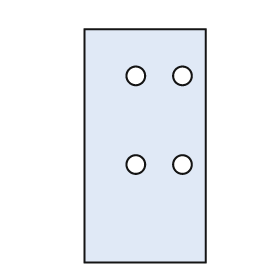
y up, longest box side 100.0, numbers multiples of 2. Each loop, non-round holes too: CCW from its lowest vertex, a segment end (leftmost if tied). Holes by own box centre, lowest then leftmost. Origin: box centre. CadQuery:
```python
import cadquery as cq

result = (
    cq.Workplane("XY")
    .moveTo(-26.0, -50.0)
    .lineTo(26.0, -50.0)
    .lineTo(26.0, 50.0)
    .lineTo(-26.0, 50.0)
    .close()
    .moveTo(-4.0, -8.0)
    .circle(4.0)
    .moveTo(16.0, -8.0)
    .circle(4.0)
    .moveTo(-4.0, 30.0)
    .circle(4.0)
    .moveTo(16.0, 30.0)
    .circle(4.0)
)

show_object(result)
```